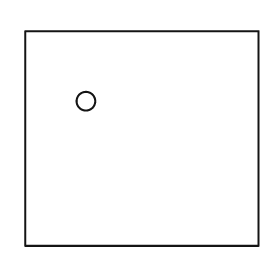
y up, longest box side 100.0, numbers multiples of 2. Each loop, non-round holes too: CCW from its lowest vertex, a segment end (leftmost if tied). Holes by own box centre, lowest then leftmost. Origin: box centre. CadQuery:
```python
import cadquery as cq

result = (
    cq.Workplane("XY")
    .moveTo(-50.0, -46.0)
    .lineTo(50.0, -46.0)
    .lineTo(50.0, 46.0)
    .lineTo(-50.0, 46.0)
    .close()
    .moveTo(-24.0, 16.0)
    .circle(4.0)
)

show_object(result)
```